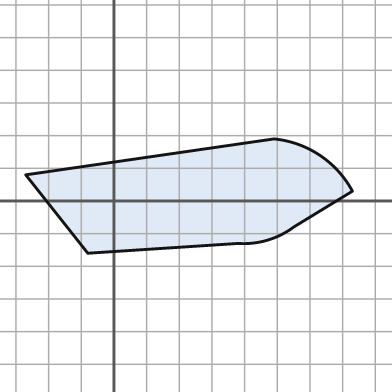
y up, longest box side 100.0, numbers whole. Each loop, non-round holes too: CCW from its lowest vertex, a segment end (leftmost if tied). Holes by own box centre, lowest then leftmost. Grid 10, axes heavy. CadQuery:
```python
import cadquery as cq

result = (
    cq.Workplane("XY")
    .moveTo(-8.0, -16.0)
    .lineTo(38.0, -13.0)
    .threePointArc((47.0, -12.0), (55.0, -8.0))
    .lineTo(73.0, 3.0)
    .threePointArc((63.0, 14.0), (49.0, 19.0))
    .lineTo(-27.0, 8.0)
    .close()
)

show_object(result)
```